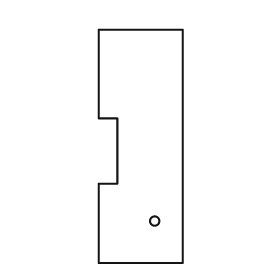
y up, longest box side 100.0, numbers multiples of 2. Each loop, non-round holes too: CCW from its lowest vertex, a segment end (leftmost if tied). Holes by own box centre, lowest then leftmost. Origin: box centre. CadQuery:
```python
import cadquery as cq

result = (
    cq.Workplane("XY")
    .moveTo(-18.0, -50.0)
    .lineTo(18.0, -50.0)
    .lineTo(18.0, 50.0)
    .lineTo(-18.0, 50.0)
    .lineTo(-18.0, 12.0)
    .lineTo(-10.0, 12.0)
    .lineTo(-10.0, -16.0)
    .lineTo(-18.0, -16.0)
    .close()
    .moveTo(6.0, -32.0)
    .circle(2.0)
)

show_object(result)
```